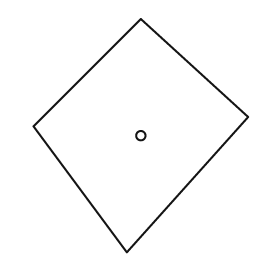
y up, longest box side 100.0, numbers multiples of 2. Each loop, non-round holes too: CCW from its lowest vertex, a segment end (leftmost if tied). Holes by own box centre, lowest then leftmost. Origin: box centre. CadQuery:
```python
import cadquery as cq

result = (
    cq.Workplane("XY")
    .moveTo(-6.0, -50.0)
    .lineTo(46.0, 8.0)
    .lineTo(0.0, 50.0)
    .lineTo(-46.0, 4.0)
    .close()
    .moveTo(0.0, 0.0)
    .circle(2.0)
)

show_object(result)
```